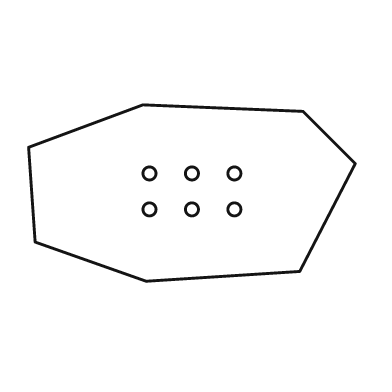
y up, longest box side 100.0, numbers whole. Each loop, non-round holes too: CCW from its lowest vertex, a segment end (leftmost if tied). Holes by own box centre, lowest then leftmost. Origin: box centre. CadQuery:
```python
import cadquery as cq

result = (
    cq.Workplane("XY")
    .moveTo(-14.0, -27.0)
    .lineTo(33.0, -24.0)
    .lineTo(50.0, 9.0)
    .lineTo(34.0, 25.0)
    .lineTo(-15.0, 27.0)
    .lineTo(-50.0, 14.0)
    .lineTo(-48.0, -15.0)
    .close()
    .moveTo(-13.0, -5.0)
    .circle(2.0)
    .moveTo(0.0, -5.0)
    .circle(2.0)
    .moveTo(13.0, -5.0)
    .circle(2.0)
    .moveTo(-13.0, 6.0)
    .circle(2.0)
    .moveTo(0.0, 6.0)
    .circle(2.0)
    .moveTo(13.0, 6.0)
    .circle(2.0)
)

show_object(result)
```